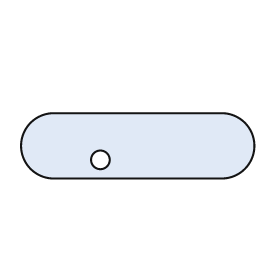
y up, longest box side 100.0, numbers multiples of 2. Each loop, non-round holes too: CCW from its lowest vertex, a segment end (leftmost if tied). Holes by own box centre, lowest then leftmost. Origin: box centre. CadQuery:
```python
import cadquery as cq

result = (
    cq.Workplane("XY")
    .moveTo(-36.0, -14.0)
    .lineTo(36.0, -14.0)
    .threePointArc((50.0, 0.0), (36.0, 14.0))
    .lineTo(-36.0, 14.0)
    .threePointArc((-50.0, 0.0), (-36.0, -14.0))
    .close()
    .moveTo(-16.0, -6.0)
    .circle(4.0)
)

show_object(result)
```